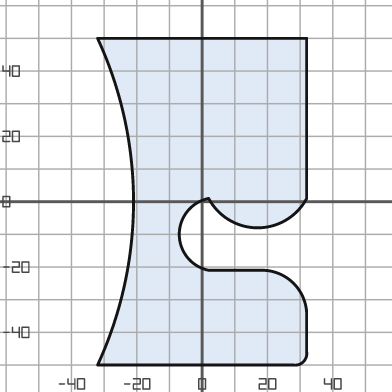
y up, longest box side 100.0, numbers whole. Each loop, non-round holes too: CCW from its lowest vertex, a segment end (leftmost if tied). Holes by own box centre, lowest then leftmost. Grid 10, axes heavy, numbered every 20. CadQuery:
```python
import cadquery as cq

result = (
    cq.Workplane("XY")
    .moveTo(-32.0, -50.0)
    .lineTo(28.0, -50.0)
    .threePointArc((31.0, -49.0), (32.0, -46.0))
    .lineTo(32.0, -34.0)
    .threePointArc((28.0, -25.0), (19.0, -21.0))
    .lineTo(2.0, -21.0)
    .threePointArc((-7.0, -10.0), (2.0, 1.0))
    .threePointArc((17.0, -8.0), (32.0, 1.0))
    .lineTo(32.0, 50.0)
    .lineTo(-32.0, 50.0)
    .threePointArc((-21.0, 0.0), (-32.0, -50.0))
    .close()
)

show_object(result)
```